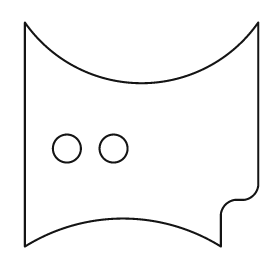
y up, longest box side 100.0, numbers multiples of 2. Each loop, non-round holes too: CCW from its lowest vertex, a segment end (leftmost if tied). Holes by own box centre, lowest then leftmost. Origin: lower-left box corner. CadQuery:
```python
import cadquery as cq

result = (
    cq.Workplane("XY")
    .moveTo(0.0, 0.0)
    .threePointArc((42.0, 12.0), (84.0, 0.0))
    .lineTo(84.0, 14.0)
    .threePointArc((86.0, 18.0), (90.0, 20.0))
    .lineTo(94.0, 20.0)
    .threePointArc((98.0, 22.0), (100.0, 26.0))
    .lineTo(100.0, 96.0)
    .threePointArc((50.0, 70.0), (0.0, 96.0))
    .close()
    .moveTo(18.0, 42.0)
    .circle(6.0)
    .moveTo(38.0, 42.0)
    .circle(6.0)
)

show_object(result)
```